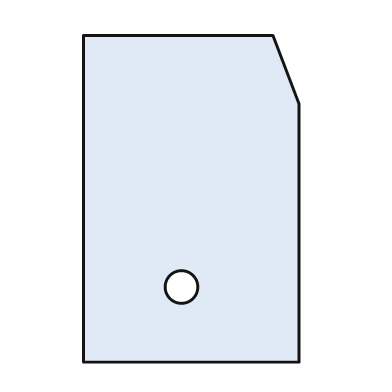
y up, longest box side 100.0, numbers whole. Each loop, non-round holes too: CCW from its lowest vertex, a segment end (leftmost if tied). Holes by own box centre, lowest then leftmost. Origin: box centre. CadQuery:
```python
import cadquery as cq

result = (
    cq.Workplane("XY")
    .moveTo(-33.0, -50.0)
    .lineTo(33.0, -50.0)
    .lineTo(33.0, 29.0)
    .lineTo(25.0, 50.0)
    .lineTo(-33.0, 50.0)
    .close()
    .moveTo(-3.0, -27.0)
    .circle(5.0)
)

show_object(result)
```